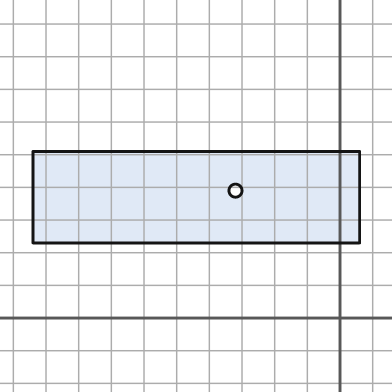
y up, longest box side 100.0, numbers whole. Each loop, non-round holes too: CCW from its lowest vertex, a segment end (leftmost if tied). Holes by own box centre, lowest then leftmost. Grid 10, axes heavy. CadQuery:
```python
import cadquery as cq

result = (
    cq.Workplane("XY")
    .moveTo(-94.0, 23.0)
    .lineTo(6.0, 23.0)
    .lineTo(6.0, 51.0)
    .lineTo(-94.0, 51.0)
    .close()
    .moveTo(-32.0, 39.0)
    .circle(2.0)
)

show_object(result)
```